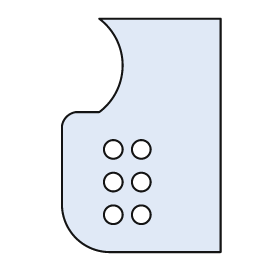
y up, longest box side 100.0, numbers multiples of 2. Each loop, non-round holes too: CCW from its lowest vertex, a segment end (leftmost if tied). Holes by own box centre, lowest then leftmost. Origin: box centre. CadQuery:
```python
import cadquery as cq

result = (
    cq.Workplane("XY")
    .moveTo(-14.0, -50.0)
    .lineTo(34.0, -50.0)
    .lineTo(34.0, 50.0)
    .lineTo(-18.0, 50.0)
    .threePointArc((-8.0, 30.0), (-18.0, 10.0))
    .lineTo(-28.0, 10.0)
    .threePointArc((-32.0, 8.0), (-34.0, 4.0))
    .lineTo(-34.0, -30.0)
    .threePointArc((-28.0, -44.0), (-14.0, -50.0))
    .close()
    .moveTo(-12.0, -34.0)
    .circle(4.0)
    .moveTo(0.0, -34.0)
    .circle(4.0)
    .moveTo(-12.0, -20.0)
    .circle(4.0)
    .moveTo(0.0, -20.0)
    .circle(4.0)
    .moveTo(-12.0, -6.0)
    .circle(4.0)
    .moveTo(0.0, -6.0)
    .circle(4.0)
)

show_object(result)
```